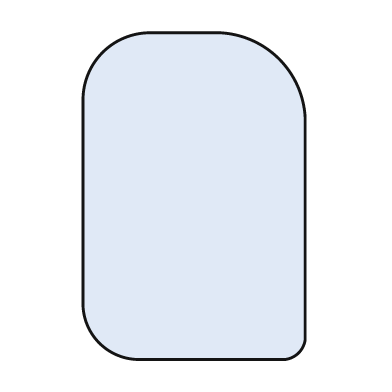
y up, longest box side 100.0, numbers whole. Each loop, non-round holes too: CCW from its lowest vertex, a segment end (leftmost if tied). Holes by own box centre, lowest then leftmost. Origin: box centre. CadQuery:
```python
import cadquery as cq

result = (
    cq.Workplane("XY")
    .moveTo(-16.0, -50.0)
    .lineTo(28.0, -50.0)
    .threePointArc((32.0, -48.0), (34.0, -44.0))
    .lineTo(34.0, 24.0)
    .threePointArc((26.0, 42.0), (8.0, 50.0))
    .lineTo(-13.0, 50.0)
    .threePointArc((-28.0, 44.0), (-34.0, 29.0))
    .lineTo(-34.0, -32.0)
    .threePointArc((-29.0, -45.0), (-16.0, -50.0))
    .close()
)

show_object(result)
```